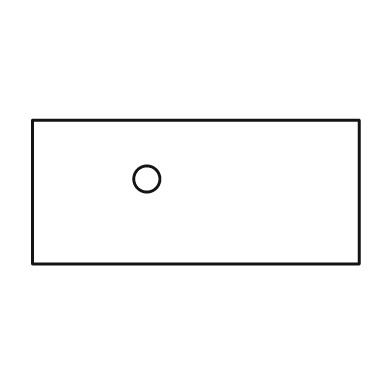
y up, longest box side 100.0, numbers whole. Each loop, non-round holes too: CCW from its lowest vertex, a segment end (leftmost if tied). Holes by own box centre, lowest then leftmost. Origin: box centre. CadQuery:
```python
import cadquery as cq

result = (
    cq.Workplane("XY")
    .moveTo(-50.0, -22.0)
    .lineTo(50.0, -22.0)
    .lineTo(50.0, 22.0)
    .lineTo(-50.0, 22.0)
    .close()
    .moveTo(-15.0, 4.0)
    .circle(4.0)
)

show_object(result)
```